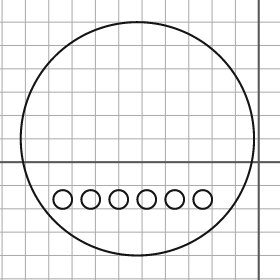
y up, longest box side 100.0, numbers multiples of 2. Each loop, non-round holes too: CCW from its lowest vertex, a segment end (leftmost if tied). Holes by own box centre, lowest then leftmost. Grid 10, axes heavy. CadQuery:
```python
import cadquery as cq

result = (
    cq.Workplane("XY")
    .moveTo(-52.0, 10.0)
    .circle(50.0)
    .moveTo(-84.0, -16.0)
    .circle(4.0)
    .moveTo(-72.0, -16.0)
    .circle(4.0)
    .moveTo(-60.0, -16.0)
    .circle(4.0)
    .moveTo(-48.0, -16.0)
    .circle(4.0)
    .moveTo(-36.0, -16.0)
    .circle(4.0)
    .moveTo(-24.0, -16.0)
    .circle(4.0)
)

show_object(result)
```